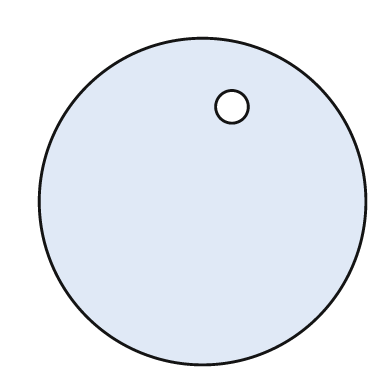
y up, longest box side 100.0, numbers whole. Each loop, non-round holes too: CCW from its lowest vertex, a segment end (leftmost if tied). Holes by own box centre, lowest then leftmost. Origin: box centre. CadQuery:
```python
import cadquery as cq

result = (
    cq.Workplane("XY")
    .moveTo(0.0, 0.0)
    .circle(50.0)
    .moveTo(9.0, 29.0)
    .circle(5.0)
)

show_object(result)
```